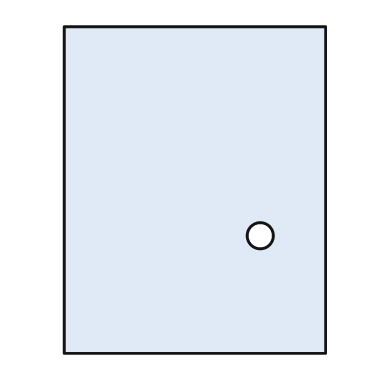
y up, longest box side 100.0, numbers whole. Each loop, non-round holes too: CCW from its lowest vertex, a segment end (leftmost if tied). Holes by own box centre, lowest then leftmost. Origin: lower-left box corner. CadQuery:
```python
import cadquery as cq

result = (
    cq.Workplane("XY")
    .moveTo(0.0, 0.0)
    .lineTo(80.0, 0.0)
    .lineTo(80.0, 100.0)
    .lineTo(0.0, 100.0)
    .close()
    .moveTo(60.0, 36.0)
    .circle(4.0)
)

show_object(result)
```